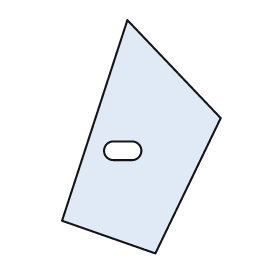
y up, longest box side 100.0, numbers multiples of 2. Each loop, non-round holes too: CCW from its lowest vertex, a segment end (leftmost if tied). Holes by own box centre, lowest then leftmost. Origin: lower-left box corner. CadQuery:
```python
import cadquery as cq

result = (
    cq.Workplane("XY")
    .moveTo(40.0, 0.0)
    .lineTo(68.0, 58.0)
    .lineTo(28.0, 100.0)
    .lineTo(0.0, 14.0)
    .close()
    .moveTo(22.0, 40.0)
    .lineTo(30.0, 40.0)
    .threePointArc((34.0, 44.0), (30.0, 48.0))
    .lineTo(22.0, 48.0)
    .threePointArc((18.0, 44.0), (22.0, 40.0))
    .close()
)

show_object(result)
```